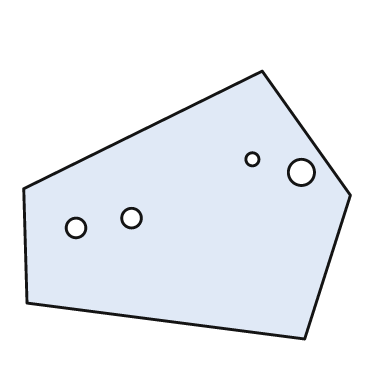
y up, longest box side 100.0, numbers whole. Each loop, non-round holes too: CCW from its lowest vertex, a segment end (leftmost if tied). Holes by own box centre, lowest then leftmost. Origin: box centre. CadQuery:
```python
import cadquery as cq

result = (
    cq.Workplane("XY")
    .moveTo(36.0, -41.0)
    .lineTo(50.0, 3.0)
    .lineTo(23.0, 41.0)
    .lineTo(-50.0, 5.0)
    .lineTo(-49.0, -30.0)
    .close()
    .moveTo(-34.0, -7.0)
    .circle(3.0)
    .moveTo(-17.0, -4.0)
    .circle(3.0)
    .moveTo(35.0, 10.0)
    .circle(4.0)
    .moveTo(20.0, 14.0)
    .circle(2.0)
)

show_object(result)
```